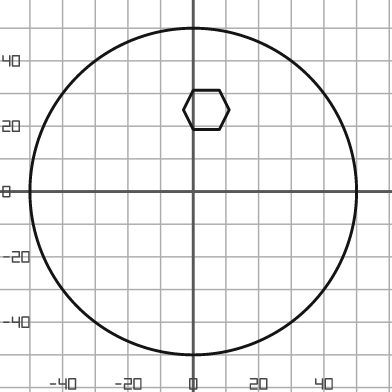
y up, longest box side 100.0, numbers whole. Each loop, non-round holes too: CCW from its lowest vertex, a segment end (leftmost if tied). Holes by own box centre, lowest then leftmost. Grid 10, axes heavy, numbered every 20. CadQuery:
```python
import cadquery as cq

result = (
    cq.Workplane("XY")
    .moveTo(0.0, 0.0)
    .circle(50.0)
    .moveTo(0.0, 19.0)
    .lineTo(8.0, 19.0)
    .lineTo(11.0, 25.0)
    .lineTo(8.0, 31.0)
    .lineTo(0.0, 31.0)
    .lineTo(-3.0, 25.0)
    .close()
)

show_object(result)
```